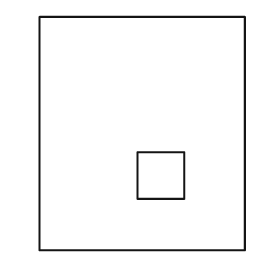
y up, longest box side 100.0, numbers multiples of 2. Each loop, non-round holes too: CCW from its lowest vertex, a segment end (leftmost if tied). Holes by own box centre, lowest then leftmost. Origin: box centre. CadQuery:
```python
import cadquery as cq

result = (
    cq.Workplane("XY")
    .moveTo(-44.0, -50.0)
    .lineTo(44.0, -50.0)
    .lineTo(44.0, 50.0)
    .lineTo(-44.0, 50.0)
    .close()
    .moveTo(-2.0, -28.0)
    .lineTo(18.0, -28.0)
    .lineTo(18.0, -8.0)
    .lineTo(-2.0, -8.0)
    .close()
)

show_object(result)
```